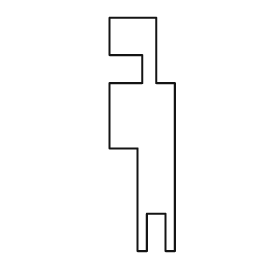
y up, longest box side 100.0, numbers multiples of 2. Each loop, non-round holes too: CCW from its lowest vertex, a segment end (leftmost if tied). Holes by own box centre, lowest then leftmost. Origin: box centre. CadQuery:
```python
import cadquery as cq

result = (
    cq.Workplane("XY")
    .moveTo(-2.0, -50.0)
    .lineTo(2.0, -50.0)
    .lineTo(2.0, -34.0)
    .lineTo(10.0, -34.0)
    .lineTo(10.0, -50.0)
    .lineTo(14.0, -50.0)
    .lineTo(14.0, 22.0)
    .lineTo(6.0, 22.0)
    .lineTo(6.0, 50.0)
    .lineTo(-14.0, 50.0)
    .lineTo(-14.0, 34.0)
    .lineTo(0.0, 34.0)
    .lineTo(0.0, 22.0)
    .lineTo(-14.0, 22.0)
    .lineTo(-14.0, -6.0)
    .lineTo(-2.0, -6.0)
    .close()
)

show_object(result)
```